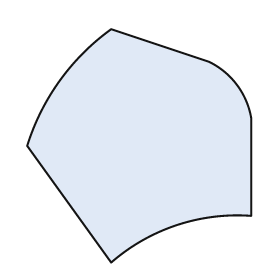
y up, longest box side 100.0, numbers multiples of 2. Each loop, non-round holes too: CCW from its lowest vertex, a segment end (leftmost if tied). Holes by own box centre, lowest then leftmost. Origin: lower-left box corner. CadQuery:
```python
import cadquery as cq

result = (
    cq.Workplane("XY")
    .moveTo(36.0, 0.0)
    .threePointArc((64.0, 16.0), (96.0, 20.0))
    .lineTo(96.0, 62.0)
    .threePointArc((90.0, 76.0), (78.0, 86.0))
    .lineTo(36.0, 100.0)
    .threePointArc((14.0, 78.0), (0.0, 50.0))
    .close()
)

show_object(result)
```